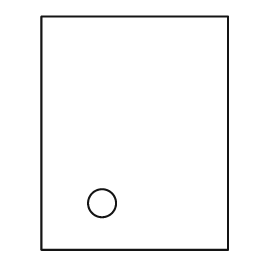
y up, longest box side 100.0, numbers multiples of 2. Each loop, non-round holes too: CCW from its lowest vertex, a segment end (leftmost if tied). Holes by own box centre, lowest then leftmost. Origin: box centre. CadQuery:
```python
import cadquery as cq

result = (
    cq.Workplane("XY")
    .moveTo(-40.0, -50.0)
    .lineTo(40.0, -50.0)
    .lineTo(40.0, 50.0)
    .lineTo(-40.0, 50.0)
    .close()
    .moveTo(-14.0, -30.0)
    .circle(6.0)
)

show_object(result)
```